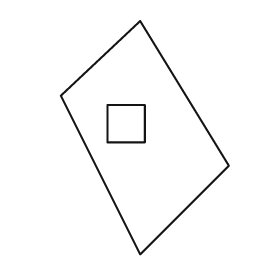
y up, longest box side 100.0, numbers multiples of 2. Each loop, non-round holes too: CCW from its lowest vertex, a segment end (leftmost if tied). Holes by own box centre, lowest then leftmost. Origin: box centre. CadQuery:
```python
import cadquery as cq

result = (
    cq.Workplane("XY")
    .moveTo(-2.0, -50.0)
    .lineTo(36.0, -12.0)
    .lineTo(-2.0, 50.0)
    .lineTo(-36.0, 18.0)
    .close()
    .moveTo(-16.0, -2.0)
    .lineTo(0.0, -2.0)
    .lineTo(0.0, 14.0)
    .lineTo(-16.0, 14.0)
    .close()
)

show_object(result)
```